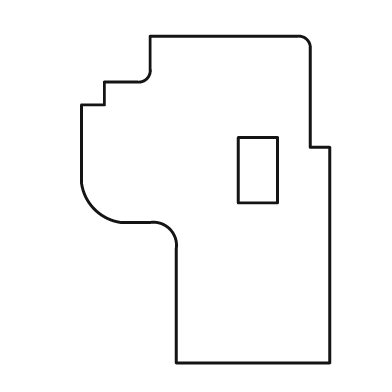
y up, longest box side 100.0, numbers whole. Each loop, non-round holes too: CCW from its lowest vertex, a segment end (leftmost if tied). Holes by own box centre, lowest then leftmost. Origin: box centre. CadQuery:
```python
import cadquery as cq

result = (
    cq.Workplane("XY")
    .moveTo(-9.0, -50.0)
    .lineTo(38.0, -50.0)
    .lineTo(38.0, 16.0)
    .lineTo(32.0, 16.0)
    .lineTo(32.0, 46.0)
    .threePointArc((31.0, 49.0), (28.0, 50.0))
    .lineTo(-17.0, 50.0)
    .lineTo(-17.0, 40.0)
    .threePointArc((-18.0, 37.0), (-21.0, 36.0))
    .lineTo(-31.0, 36.0)
    .lineTo(-31.0, 29.0)
    .lineTo(-38.0, 29.0)
    .lineTo(-38.0, 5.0)
    .threePointArc((-34.0, -3.0), (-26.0, -7.0))
    .lineTo(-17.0, -7.0)
    .threePointArc((-11.0, -9.0), (-9.0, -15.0))
    .close()
    .moveTo(10.0, -1.0)
    .lineTo(22.0, -1.0)
    .lineTo(22.0, 19.0)
    .lineTo(10.0, 19.0)
    .close()
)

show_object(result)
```